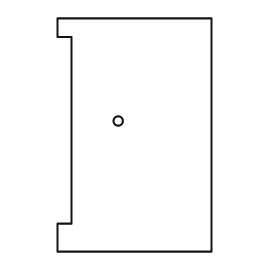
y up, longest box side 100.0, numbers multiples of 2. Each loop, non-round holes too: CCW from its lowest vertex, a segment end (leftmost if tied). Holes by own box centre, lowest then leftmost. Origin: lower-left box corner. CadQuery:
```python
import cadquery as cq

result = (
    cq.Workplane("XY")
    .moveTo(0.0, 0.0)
    .lineTo(66.0, 0.0)
    .lineTo(66.0, 100.0)
    .lineTo(0.0, 100.0)
    .lineTo(0.0, 92.0)
    .lineTo(6.0, 92.0)
    .lineTo(6.0, 12.0)
    .lineTo(0.0, 12.0)
    .close()
    .moveTo(26.0, 56.0)
    .circle(2.0)
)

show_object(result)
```